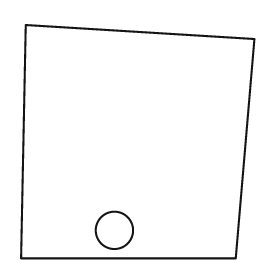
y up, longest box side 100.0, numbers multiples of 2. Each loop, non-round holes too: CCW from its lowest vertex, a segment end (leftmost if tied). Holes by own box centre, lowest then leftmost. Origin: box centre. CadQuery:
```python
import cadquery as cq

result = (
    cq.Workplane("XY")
    .moveTo(-50.0, -50.0)
    .lineTo(42.0, -50.0)
    .lineTo(50.0, 44.0)
    .lineTo(-48.0, 50.0)
    .close()
    .moveTo(-10.0, -38.0)
    .circle(8.0)
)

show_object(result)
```